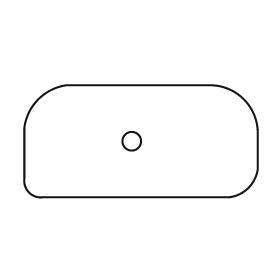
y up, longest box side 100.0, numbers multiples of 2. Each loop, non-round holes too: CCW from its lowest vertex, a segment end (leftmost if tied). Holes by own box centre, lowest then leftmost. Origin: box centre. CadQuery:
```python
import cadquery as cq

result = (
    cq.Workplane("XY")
    .moveTo(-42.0, -24.0)
    .lineTo(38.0, -24.0)
    .threePointArc((46.0, -20.0), (50.0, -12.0))
    .lineTo(50.0, 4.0)
    .threePointArc((44.0, 18.0), (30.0, 24.0))
    .lineTo(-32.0, 24.0)
    .threePointArc((-44.0, 18.0), (-50.0, 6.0))
    .lineTo(-50.0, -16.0)
    .threePointArc((-48.0, -22.0), (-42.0, -24.0))
    .close()
    .moveTo(-4.0, 0.0)
    .circle(4.0)
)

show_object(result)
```